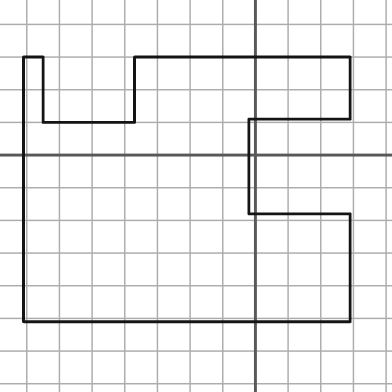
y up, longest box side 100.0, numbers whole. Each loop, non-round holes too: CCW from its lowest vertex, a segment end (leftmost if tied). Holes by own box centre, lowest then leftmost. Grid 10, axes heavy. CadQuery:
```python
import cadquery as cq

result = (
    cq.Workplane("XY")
    .moveTo(-71.0, -51.0)
    .lineTo(29.0, -51.0)
    .lineTo(29.0, -18.0)
    .lineTo(-2.0, -18.0)
    .lineTo(-2.0, 11.0)
    .lineTo(29.0, 11.0)
    .lineTo(29.0, 30.0)
    .lineTo(-37.0, 30.0)
    .lineTo(-37.0, 10.0)
    .lineTo(-65.0, 10.0)
    .lineTo(-65.0, 30.0)
    .lineTo(-71.0, 30.0)
    .close()
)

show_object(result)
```